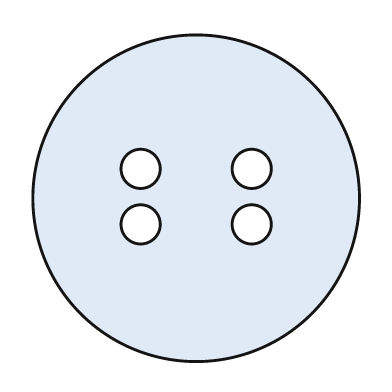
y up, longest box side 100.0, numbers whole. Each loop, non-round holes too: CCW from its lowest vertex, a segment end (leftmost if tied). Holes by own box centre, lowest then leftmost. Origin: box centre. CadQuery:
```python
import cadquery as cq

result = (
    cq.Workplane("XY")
    .moveTo(0.0, 0.0)
    .circle(50.0)
    .moveTo(-17.0, -8.0)
    .circle(6.0)
    .moveTo(17.0, -8.0)
    .circle(6.0)
    .moveTo(-17.0, 9.0)
    .circle(6.0)
    .moveTo(17.0, 9.0)
    .circle(6.0)
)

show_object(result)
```